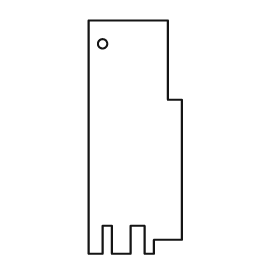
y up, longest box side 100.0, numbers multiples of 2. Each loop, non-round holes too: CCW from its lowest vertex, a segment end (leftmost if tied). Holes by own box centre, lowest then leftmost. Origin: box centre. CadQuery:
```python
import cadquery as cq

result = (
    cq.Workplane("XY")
    .moveTo(-20.0, -50.0)
    .lineTo(-14.0, -50.0)
    .lineTo(-14.0, -38.0)
    .lineTo(-10.0, -38.0)
    .lineTo(-10.0, -50.0)
    .lineTo(-2.0, -50.0)
    .lineTo(-2.0, -38.0)
    .lineTo(4.0, -38.0)
    .lineTo(4.0, -50.0)
    .lineTo(8.0, -50.0)
    .lineTo(8.0, -44.0)
    .lineTo(20.0, -44.0)
    .lineTo(20.0, 16.0)
    .lineTo(14.0, 16.0)
    .lineTo(14.0, 50.0)
    .lineTo(-20.0, 50.0)
    .close()
    .moveTo(-14.0, 40.0)
    .circle(2.0)
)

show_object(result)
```